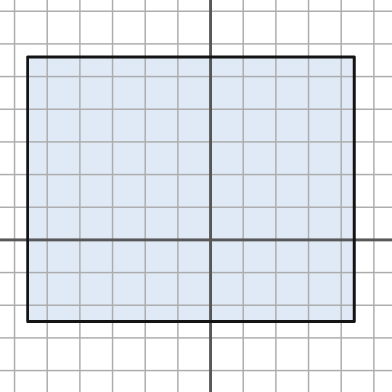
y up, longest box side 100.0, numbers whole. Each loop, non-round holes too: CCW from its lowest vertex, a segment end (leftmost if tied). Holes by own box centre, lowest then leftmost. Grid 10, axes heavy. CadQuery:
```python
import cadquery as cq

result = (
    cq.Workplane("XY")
    .moveTo(-56.0, -25.0)
    .lineTo(44.0, -25.0)
    .lineTo(44.0, 56.0)
    .lineTo(-56.0, 56.0)
    .close()
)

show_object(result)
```